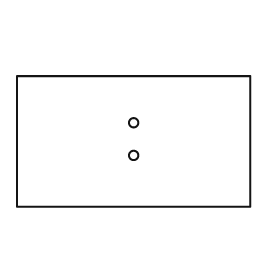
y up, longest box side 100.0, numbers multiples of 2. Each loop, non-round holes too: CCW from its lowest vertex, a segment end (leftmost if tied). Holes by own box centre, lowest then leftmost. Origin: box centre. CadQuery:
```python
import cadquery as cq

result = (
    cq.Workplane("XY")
    .moveTo(-50.0, -28.0)
    .lineTo(50.0, -28.0)
    .lineTo(50.0, 28.0)
    .lineTo(-50.0, 28.0)
    .close()
    .moveTo(0.0, -6.0)
    .circle(2.0)
    .moveTo(0.0, 8.0)
    .circle(2.0)
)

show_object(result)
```